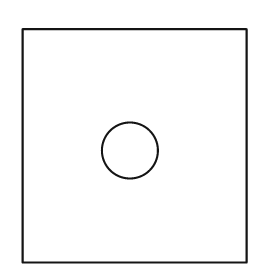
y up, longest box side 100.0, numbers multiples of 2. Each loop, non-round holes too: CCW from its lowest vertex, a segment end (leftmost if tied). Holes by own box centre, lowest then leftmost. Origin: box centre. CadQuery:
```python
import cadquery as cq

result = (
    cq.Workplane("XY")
    .moveTo(-48.0, -50.0)
    .lineTo(48.0, -50.0)
    .lineTo(48.0, 50.0)
    .lineTo(-48.0, 50.0)
    .close()
    .moveTo(-2.0, -2.0)
    .circle(12.0)
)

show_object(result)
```